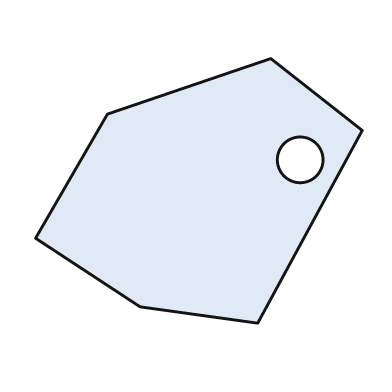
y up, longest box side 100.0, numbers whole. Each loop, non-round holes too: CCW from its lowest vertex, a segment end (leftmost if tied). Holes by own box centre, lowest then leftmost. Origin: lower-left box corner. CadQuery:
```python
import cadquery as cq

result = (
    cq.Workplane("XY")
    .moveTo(68.0, 0.0)
    .lineTo(100.0, 59.0)
    .lineTo(72.0, 81.0)
    .lineTo(22.0, 64.0)
    .lineTo(0.0, 26.0)
    .lineTo(32.0, 5.0)
    .close()
    .moveTo(81.0, 50.0)
    .circle(7.0)
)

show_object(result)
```